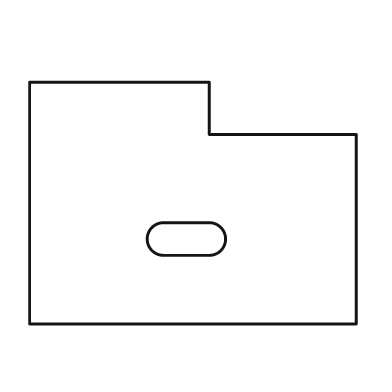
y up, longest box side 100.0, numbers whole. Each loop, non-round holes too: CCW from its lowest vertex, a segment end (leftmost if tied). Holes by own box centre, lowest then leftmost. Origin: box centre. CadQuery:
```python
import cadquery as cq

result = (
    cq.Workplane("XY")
    .moveTo(-50.0, -37.0)
    .lineTo(50.0, -37.0)
    .lineTo(50.0, 21.0)
    .lineTo(5.0, 21.0)
    .lineTo(5.0, 37.0)
    .lineTo(-50.0, 37.0)
    .close()
    .moveTo(-9.0, -16.0)
    .lineTo(5.0, -16.0)
    .threePointArc((10.0, -11.0), (5.0, -6.0))
    .lineTo(-9.0, -6.0)
    .threePointArc((-14.0, -11.0), (-9.0, -16.0))
    .close()
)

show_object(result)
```